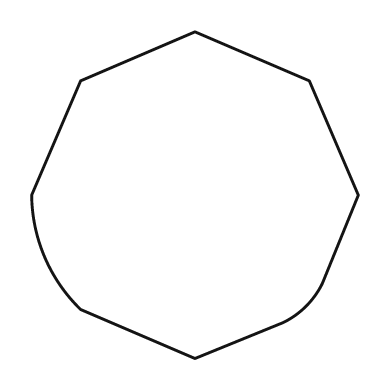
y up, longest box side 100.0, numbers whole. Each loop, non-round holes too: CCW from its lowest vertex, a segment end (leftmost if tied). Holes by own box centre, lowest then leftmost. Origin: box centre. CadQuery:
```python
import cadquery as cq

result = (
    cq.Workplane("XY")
    .moveTo(0.0, -50.0)
    .lineTo(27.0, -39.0)
    .threePointArc((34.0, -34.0), (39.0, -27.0))
    .lineTo(50.0, 0.0)
    .lineTo(35.0, 35.0)
    .lineTo(0.0, 50.0)
    .lineTo(-35.0, 35.0)
    .lineTo(-50.0, 0.0)
    .threePointArc((-46.0, -19.0), (-35.0, -35.0))
    .close()
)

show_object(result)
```